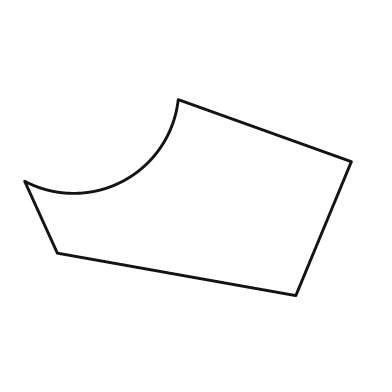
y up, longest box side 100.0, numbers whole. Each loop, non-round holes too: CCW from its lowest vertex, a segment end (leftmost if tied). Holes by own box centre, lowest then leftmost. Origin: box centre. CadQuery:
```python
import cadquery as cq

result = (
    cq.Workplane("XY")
    .moveTo(33.0, -30.0)
    .lineTo(50.0, 11.0)
    .lineTo(-3.0, 30.0)
    .threePointArc((-20.0, 5.0), (-50.0, 5.0))
    .lineTo(-40.0, -17.0)
    .close()
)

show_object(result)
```